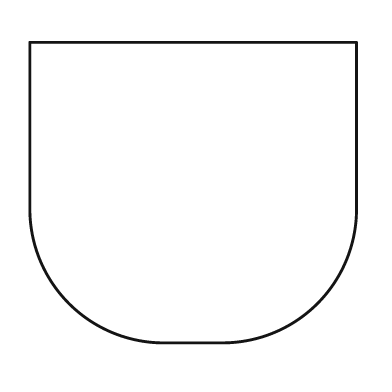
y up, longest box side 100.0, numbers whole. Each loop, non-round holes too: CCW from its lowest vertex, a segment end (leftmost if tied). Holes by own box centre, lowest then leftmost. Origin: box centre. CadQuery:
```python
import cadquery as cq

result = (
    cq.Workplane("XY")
    .moveTo(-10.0, -46.0)
    .lineTo(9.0, -46.0)
    .threePointArc((38.0, -34.0), (50.0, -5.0))
    .lineTo(50.0, 46.0)
    .lineTo(-50.0, 46.0)
    .lineTo(-50.0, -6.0)
    .threePointArc((-38.0, -34.0), (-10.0, -46.0))
    .close()
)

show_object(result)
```